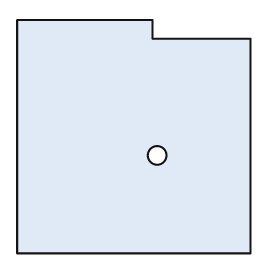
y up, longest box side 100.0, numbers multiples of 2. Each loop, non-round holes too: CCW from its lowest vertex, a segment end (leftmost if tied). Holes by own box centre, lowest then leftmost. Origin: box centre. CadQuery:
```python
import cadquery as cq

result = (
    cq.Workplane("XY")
    .moveTo(-50.0, -50.0)
    .lineTo(50.0, -50.0)
    .lineTo(50.0, 42.0)
    .lineTo(8.0, 42.0)
    .lineTo(8.0, 50.0)
    .lineTo(-50.0, 50.0)
    .close()
    .moveTo(10.0, -8.0)
    .circle(4.0)
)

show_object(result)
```